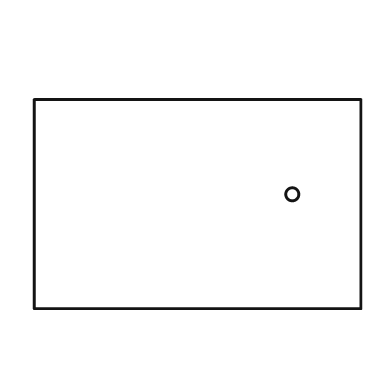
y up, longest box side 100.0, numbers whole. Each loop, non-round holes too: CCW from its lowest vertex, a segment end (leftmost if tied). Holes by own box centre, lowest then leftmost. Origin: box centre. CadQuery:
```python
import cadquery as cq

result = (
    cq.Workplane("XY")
    .moveTo(-50.0, -32.0)
    .lineTo(50.0, -32.0)
    .lineTo(50.0, 32.0)
    .lineTo(-50.0, 32.0)
    .close()
    .moveTo(29.0, 3.0)
    .circle(2.0)
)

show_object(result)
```